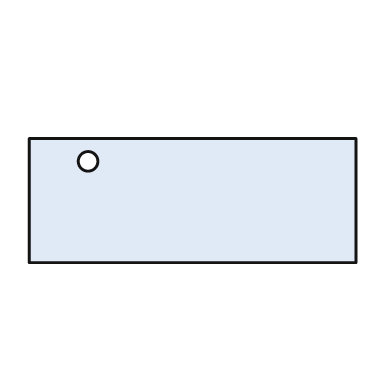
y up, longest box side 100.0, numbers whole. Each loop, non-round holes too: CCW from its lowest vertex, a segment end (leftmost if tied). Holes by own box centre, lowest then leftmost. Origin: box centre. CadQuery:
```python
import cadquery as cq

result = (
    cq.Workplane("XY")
    .moveTo(-50.0, -19.0)
    .lineTo(50.0, -19.0)
    .lineTo(50.0, 19.0)
    .lineTo(-50.0, 19.0)
    .close()
    .moveTo(-32.0, 12.0)
    .circle(3.0)
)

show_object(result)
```